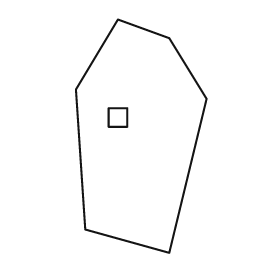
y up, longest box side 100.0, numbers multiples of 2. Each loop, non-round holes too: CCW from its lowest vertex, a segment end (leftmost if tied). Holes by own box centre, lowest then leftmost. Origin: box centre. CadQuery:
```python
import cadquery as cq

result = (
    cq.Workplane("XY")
    .moveTo(12.0, -50.0)
    .lineTo(28.0, 16.0)
    .lineTo(12.0, 42.0)
    .lineTo(-10.0, 50.0)
    .lineTo(-28.0, 20.0)
    .lineTo(-24.0, -40.0)
    .close()
    .moveTo(-14.0, 4.0)
    .lineTo(-6.0, 4.0)
    .lineTo(-6.0, 12.0)
    .lineTo(-14.0, 12.0)
    .close()
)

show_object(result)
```